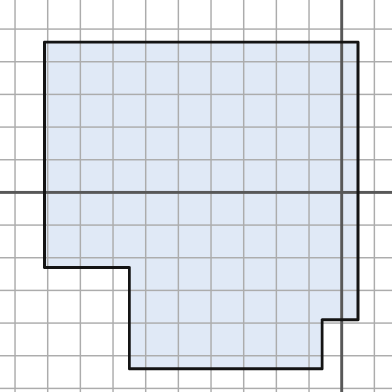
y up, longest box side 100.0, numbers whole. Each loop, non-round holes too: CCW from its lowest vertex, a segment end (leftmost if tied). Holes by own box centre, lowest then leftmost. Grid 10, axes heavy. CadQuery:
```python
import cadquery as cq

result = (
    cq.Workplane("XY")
    .moveTo(-65.0, -54.0)
    .lineTo(-6.0, -54.0)
    .lineTo(-6.0, -39.0)
    .lineTo(5.0, -39.0)
    .lineTo(5.0, 46.0)
    .lineTo(-91.0, 46.0)
    .lineTo(-91.0, -23.0)
    .lineTo(-65.0, -23.0)
    .close()
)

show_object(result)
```